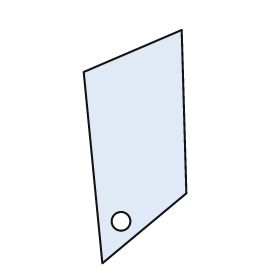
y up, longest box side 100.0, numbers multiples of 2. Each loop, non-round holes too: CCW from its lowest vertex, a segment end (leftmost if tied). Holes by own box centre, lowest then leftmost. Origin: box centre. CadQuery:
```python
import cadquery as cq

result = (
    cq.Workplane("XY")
    .moveTo(-14.0, -50.0)
    .lineTo(22.0, -20.0)
    .lineTo(20.0, 50.0)
    .lineTo(-22.0, 32.0)
    .close()
    .moveTo(-6.0, -32.0)
    .circle(4.0)
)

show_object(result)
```